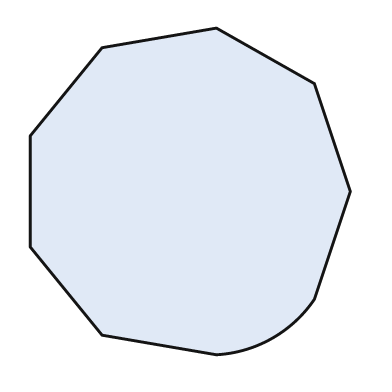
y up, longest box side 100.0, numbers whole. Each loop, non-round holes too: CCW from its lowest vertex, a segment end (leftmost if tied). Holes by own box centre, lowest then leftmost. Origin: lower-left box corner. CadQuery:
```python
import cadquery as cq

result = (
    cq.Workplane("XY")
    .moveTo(57.0, 0.0)
    .threePointArc((74.0, 5.0), (87.0, 17.0))
    .lineTo(98.0, 50.0)
    .lineTo(87.0, 83.0)
    .lineTo(57.0, 100.0)
    .lineTo(22.0, 94.0)
    .lineTo(0.0, 67.0)
    .lineTo(0.0, 33.0)
    .lineTo(22.0, 6.0)
    .close()
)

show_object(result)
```